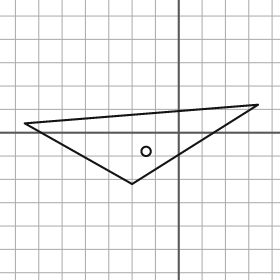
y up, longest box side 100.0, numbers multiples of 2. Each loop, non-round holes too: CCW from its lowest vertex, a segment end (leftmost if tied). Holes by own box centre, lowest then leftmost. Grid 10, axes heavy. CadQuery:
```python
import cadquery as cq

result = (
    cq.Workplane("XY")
    .moveTo(-20.0, -22.0)
    .lineTo(34.0, 12.0)
    .lineTo(-66.0, 4.0)
    .close()
    .moveTo(-14.0, -8.0)
    .circle(2.0)
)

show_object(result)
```